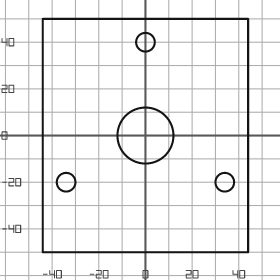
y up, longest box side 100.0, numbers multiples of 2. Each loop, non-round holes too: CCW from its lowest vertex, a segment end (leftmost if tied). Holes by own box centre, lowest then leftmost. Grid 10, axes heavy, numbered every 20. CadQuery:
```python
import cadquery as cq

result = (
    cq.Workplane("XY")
    .moveTo(-44.0, -50.0)
    .lineTo(44.0, -50.0)
    .lineTo(44.0, 50.0)
    .lineTo(-44.0, 50.0)
    .close()
    .moveTo(-34.0, -20.0)
    .circle(4.0)
    .moveTo(34.0, -20.0)
    .circle(4.0)
    .moveTo(0.0, 0.0)
    .circle(12.0)
    .moveTo(0.0, 40.0)
    .circle(4.0)
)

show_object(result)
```